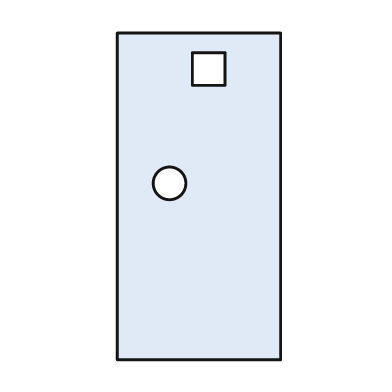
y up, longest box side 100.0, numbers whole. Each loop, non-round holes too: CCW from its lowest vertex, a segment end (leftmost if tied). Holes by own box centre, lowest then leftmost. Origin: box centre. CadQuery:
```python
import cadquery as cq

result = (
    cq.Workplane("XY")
    .moveTo(-25.0, -50.0)
    .lineTo(25.0, -50.0)
    .lineTo(25.0, 50.0)
    .lineTo(-25.0, 50.0)
    .close()
    .moveTo(-9.0, 4.0)
    .circle(5.0)
    .moveTo(-2.0, 34.0)
    .lineTo(8.0, 34.0)
    .lineTo(8.0, 44.0)
    .lineTo(-2.0, 44.0)
    .close()
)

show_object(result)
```